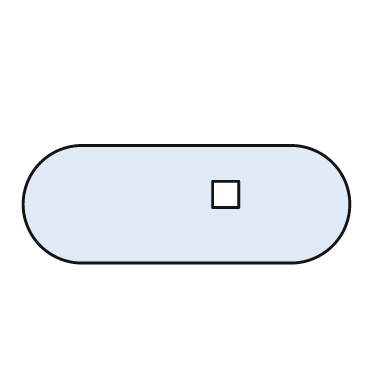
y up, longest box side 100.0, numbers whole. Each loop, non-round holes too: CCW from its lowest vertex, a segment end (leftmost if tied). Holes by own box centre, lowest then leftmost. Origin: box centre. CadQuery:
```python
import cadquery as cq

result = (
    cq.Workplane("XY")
    .moveTo(-32.0, -18.0)
    .lineTo(32.0, -18.0)
    .threePointArc((50.0, 0.0), (32.0, 18.0))
    .lineTo(-32.0, 18.0)
    .threePointArc((-50.0, 0.0), (-32.0, -18.0))
    .close()
    .moveTo(8.0, -1.0)
    .lineTo(16.0, -1.0)
    .lineTo(16.0, 7.0)
    .lineTo(8.0, 7.0)
    .close()
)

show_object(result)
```